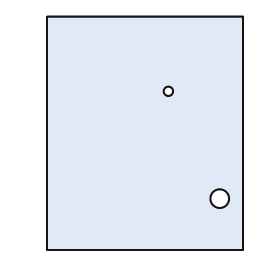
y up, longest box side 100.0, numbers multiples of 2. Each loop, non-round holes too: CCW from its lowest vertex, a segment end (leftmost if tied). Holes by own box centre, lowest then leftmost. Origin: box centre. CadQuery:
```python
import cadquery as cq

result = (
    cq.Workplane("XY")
    .moveTo(-42.0, -50.0)
    .lineTo(42.0, -50.0)
    .lineTo(42.0, 50.0)
    .lineTo(-42.0, 50.0)
    .close()
    .moveTo(32.0, -28.0)
    .circle(4.0)
    .moveTo(10.0, 18.0)
    .circle(2.0)
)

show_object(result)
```